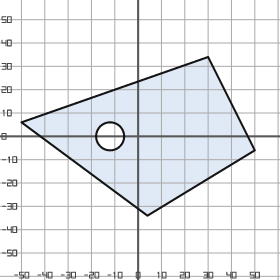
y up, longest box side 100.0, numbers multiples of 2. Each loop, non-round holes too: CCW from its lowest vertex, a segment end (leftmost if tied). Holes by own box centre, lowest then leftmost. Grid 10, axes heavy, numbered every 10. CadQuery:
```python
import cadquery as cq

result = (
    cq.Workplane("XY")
    .moveTo(4.0, -34.0)
    .lineTo(50.0, -6.0)
    .lineTo(30.0, 34.0)
    .lineTo(-50.0, 6.0)
    .close()
    .moveTo(-12.0, 0.0)
    .circle(6.0)
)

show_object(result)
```